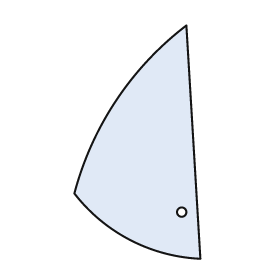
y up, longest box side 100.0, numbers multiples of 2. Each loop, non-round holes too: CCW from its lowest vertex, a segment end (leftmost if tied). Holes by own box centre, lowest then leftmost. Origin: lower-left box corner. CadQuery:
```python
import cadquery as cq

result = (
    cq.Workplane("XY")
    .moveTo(54.0, 0.0)
    .lineTo(48.0, 100.0)
    .threePointArc((18.0, 68.0), (0.0, 28.0))
    .threePointArc((24.0, 8.0), (54.0, 0.0))
    .close()
    .moveTo(46.0, 20.0)
    .circle(2.0)
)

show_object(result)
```